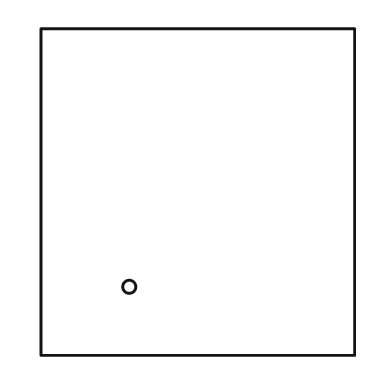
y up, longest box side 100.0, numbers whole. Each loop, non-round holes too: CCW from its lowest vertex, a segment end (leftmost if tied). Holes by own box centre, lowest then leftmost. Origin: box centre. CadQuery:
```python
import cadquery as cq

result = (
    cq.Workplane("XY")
    .moveTo(-48.0, -50.0)
    .lineTo(48.0, -50.0)
    .lineTo(48.0, 50.0)
    .lineTo(-48.0, 50.0)
    .close()
    .moveTo(-21.0, -29.0)
    .circle(2.0)
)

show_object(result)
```